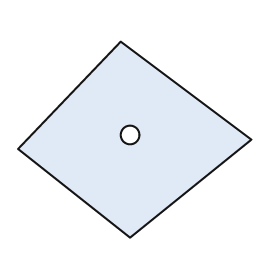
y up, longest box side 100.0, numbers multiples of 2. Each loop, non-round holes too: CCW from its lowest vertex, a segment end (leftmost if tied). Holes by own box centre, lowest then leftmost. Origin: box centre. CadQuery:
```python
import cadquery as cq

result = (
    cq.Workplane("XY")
    .moveTo(-2.0, -42.0)
    .lineTo(50.0, 0.0)
    .lineTo(-6.0, 42.0)
    .lineTo(-50.0, -4.0)
    .close()
    .moveTo(-2.0, 2.0)
    .circle(4.0)
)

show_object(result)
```